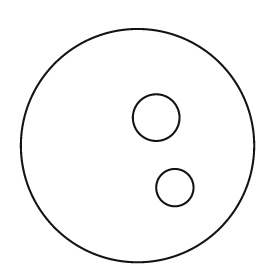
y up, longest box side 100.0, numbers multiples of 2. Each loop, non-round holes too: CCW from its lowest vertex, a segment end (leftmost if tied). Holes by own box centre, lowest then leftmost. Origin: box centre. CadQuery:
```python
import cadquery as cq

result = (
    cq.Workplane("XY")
    .moveTo(0.0, 0.0)
    .circle(50.0)
    .moveTo(16.0, -18.0)
    .circle(8.0)
    .moveTo(8.0, 12.0)
    .circle(10.0)
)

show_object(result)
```